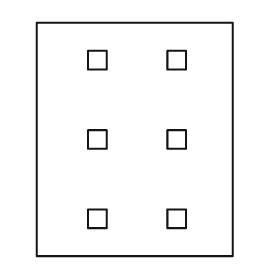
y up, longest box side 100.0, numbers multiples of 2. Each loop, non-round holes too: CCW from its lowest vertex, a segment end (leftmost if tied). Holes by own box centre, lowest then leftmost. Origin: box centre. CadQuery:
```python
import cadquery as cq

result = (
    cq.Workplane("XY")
    .moveTo(-42.0, -50.0)
    .lineTo(42.0, -50.0)
    .lineTo(42.0, 50.0)
    .lineTo(-42.0, 50.0)
    .close()
    .moveTo(-20.0, -38.0)
    .lineTo(-12.0, -38.0)
    .lineTo(-12.0, -30.0)
    .lineTo(-20.0, -30.0)
    .close()
    .moveTo(14.0, -38.0)
    .lineTo(22.0, -38.0)
    .lineTo(22.0, -30.0)
    .lineTo(14.0, -30.0)
    .close()
    .moveTo(-20.0, -4.0)
    .lineTo(-12.0, -4.0)
    .lineTo(-12.0, 4.0)
    .lineTo(-20.0, 4.0)
    .close()
    .moveTo(14.0, -4.0)
    .lineTo(22.0, -4.0)
    .lineTo(22.0, 4.0)
    .lineTo(14.0, 4.0)
    .close()
    .moveTo(-20.0, 30.0)
    .lineTo(-12.0, 30.0)
    .lineTo(-12.0, 38.0)
    .lineTo(-20.0, 38.0)
    .close()
    .moveTo(14.0, 30.0)
    .lineTo(22.0, 30.0)
    .lineTo(22.0, 38.0)
    .lineTo(14.0, 38.0)
    .close()
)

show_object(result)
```